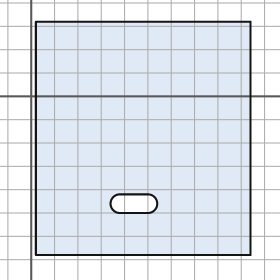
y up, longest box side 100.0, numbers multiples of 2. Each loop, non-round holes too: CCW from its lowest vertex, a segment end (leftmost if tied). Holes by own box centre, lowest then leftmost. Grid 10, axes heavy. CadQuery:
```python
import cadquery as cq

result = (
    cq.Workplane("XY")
    .moveTo(2.0, -68.0)
    .lineTo(94.0, -68.0)
    .lineTo(94.0, 32.0)
    .lineTo(2.0, 32.0)
    .close()
    .moveTo(38.0, -50.0)
    .lineTo(50.0, -50.0)
    .threePointArc((54.0, -46.0), (50.0, -42.0))
    .lineTo(38.0, -42.0)
    .threePointArc((34.0, -46.0), (38.0, -50.0))
    .close()
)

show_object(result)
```